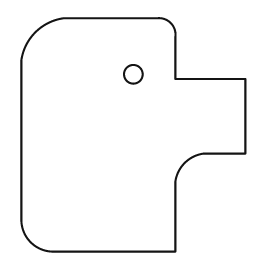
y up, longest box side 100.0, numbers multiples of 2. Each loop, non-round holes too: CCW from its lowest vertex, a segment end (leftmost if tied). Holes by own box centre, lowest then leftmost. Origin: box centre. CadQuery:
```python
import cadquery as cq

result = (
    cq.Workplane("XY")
    .moveTo(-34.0, -50.0)
    .lineTo(18.0, -50.0)
    .lineTo(18.0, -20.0)
    .threePointArc((22.0, -12.0), (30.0, -8.0))
    .lineTo(48.0, -8.0)
    .lineTo(48.0, 24.0)
    .lineTo(18.0, 24.0)
    .lineTo(18.0, 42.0)
    .threePointArc((16.0, 48.0), (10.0, 50.0))
    .lineTo(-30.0, 50.0)
    .threePointArc((-42.0, 44.0), (-48.0, 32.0))
    .lineTo(-48.0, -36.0)
    .threePointArc((-44.0, -46.0), (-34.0, -50.0))
    .close()
    .moveTo(0.0, 26.0)
    .circle(4.0)
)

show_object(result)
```